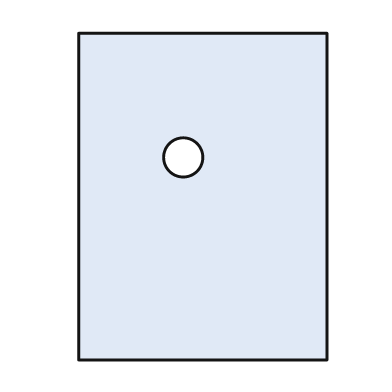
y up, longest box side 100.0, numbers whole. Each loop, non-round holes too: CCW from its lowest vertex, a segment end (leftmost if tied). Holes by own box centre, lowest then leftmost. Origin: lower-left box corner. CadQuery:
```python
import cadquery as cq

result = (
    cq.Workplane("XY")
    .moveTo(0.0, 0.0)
    .lineTo(76.0, 0.0)
    .lineTo(76.0, 100.0)
    .lineTo(0.0, 100.0)
    .close()
    .moveTo(32.0, 62.0)
    .circle(6.0)
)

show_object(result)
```